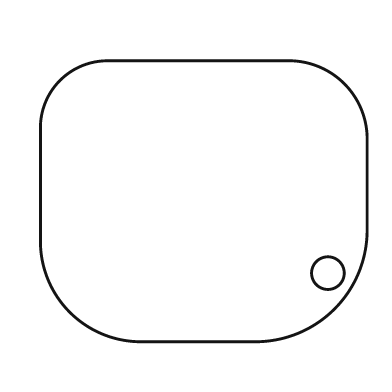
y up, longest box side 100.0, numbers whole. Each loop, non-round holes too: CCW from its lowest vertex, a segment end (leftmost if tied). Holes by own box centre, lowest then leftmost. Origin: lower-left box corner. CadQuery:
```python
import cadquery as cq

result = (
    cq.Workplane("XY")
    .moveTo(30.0, 0.0)
    .lineTo(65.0, 0.0)
    .threePointArc((90.0, 10.0), (100.0, 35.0))
    .lineTo(100.0, 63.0)
    .threePointArc((93.0, 79.0), (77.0, 86.0))
    .lineTo(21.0, 86.0)
    .threePointArc((6.0, 80.0), (0.0, 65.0))
    .lineTo(0.0, 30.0)
    .threePointArc((9.0, 9.0), (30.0, 0.0))
    .close()
    .moveTo(88.0, 21.0)
    .circle(5.0)
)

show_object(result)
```